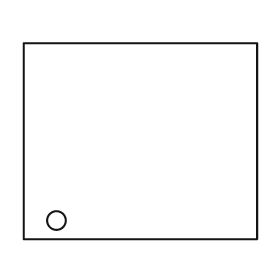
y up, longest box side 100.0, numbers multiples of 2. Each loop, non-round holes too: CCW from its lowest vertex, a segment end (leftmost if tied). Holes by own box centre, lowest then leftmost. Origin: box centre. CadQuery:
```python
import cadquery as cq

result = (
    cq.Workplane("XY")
    .moveTo(-50.0, -42.0)
    .lineTo(50.0, -42.0)
    .lineTo(50.0, 42.0)
    .lineTo(-50.0, 42.0)
    .close()
    .moveTo(-36.0, -34.0)
    .circle(4.0)
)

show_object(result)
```